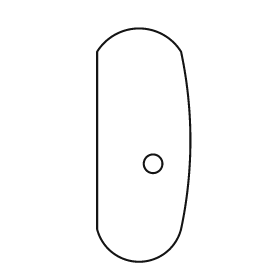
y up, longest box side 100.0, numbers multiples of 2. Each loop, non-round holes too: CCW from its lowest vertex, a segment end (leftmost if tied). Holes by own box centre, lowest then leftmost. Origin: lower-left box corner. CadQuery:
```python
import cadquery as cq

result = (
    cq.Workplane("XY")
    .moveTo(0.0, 14.0)
    .threePointArc((18.0, 0.0), (36.0, 14.0))
    .threePointArc((40.0, 52.0), (36.0, 90.0))
    .threePointArc((18.0, 100.0), (0.0, 90.0))
    .close()
    .moveTo(24.0, 42.0)
    .circle(4.0)
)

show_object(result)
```